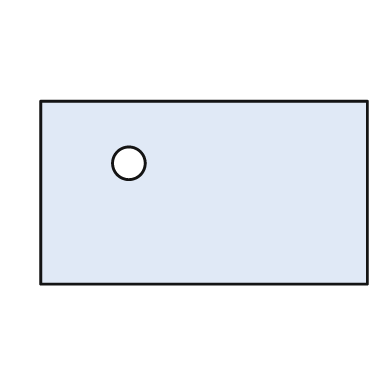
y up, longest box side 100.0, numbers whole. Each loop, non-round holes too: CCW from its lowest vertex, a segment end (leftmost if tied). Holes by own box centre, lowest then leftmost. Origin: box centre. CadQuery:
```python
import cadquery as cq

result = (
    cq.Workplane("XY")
    .moveTo(-50.0, -28.0)
    .lineTo(50.0, -28.0)
    .lineTo(50.0, 28.0)
    .lineTo(-50.0, 28.0)
    .close()
    .moveTo(-23.0, 9.0)
    .circle(5.0)
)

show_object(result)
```